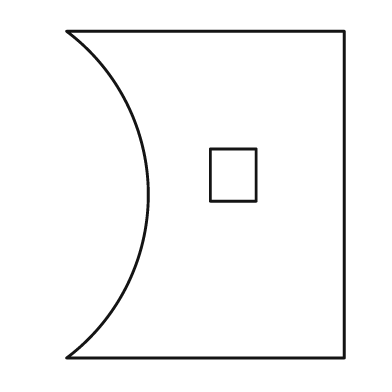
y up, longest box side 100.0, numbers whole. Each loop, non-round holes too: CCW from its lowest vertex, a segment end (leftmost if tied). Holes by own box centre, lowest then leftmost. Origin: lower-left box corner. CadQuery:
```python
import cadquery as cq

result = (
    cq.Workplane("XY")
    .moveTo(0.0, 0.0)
    .lineTo(85.0, 0.0)
    .lineTo(85.0, 100.0)
    .lineTo(0.0, 100.0)
    .threePointArc((25.0, 50.0), (0.0, 0.0))
    .close()
    .moveTo(44.0, 48.0)
    .lineTo(58.0, 48.0)
    .lineTo(58.0, 64.0)
    .lineTo(44.0, 64.0)
    .close()
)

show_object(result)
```